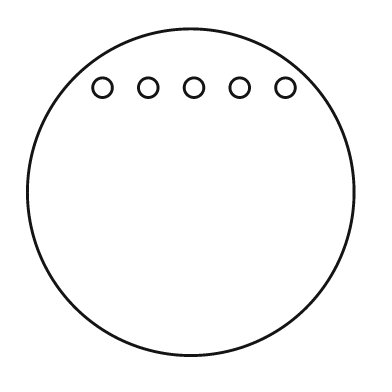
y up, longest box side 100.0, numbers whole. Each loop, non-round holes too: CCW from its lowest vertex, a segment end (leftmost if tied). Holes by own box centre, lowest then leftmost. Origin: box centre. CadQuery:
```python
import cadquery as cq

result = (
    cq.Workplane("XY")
    .moveTo(0.0, 0.0)
    .circle(50.0)
    .moveTo(-27.0, 32.0)
    .circle(3.0)
    .moveTo(-13.0, 32.0)
    .circle(3.0)
    .moveTo(1.0, 32.0)
    .circle(3.0)
    .moveTo(15.0, 32.0)
    .circle(3.0)
    .moveTo(29.0, 32.0)
    .circle(3.0)
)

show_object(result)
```